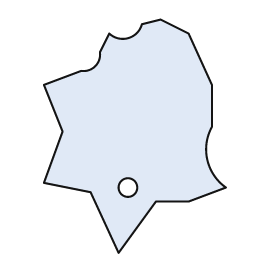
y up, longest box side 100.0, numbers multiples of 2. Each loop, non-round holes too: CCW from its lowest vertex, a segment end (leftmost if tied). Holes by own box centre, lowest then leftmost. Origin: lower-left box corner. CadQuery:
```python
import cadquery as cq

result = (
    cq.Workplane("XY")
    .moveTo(32.0, 0.0)
    .lineTo(48.0, 22.0)
    .lineTo(62.0, 22.0)
    .lineTo(78.0, 28.0)
    .threePointArc((70.0, 40.0), (72.0, 54.0))
    .lineTo(72.0, 72.0)
    .lineTo(62.0, 94.0)
    .lineTo(50.0, 100.0)
    .lineTo(42.0, 98.0)
    .threePointArc((36.0, 92.0), (28.0, 94.0))
    .lineTo(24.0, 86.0)
    .threePointArc((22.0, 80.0), (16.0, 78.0))
    .lineTo(0.0, 72.0)
    .lineTo(8.0, 52.0)
    .lineTo(0.0, 30.0)
    .lineTo(20.0, 26.0)
    .close()
    .moveTo(36.0, 28.0)
    .circle(4.0)
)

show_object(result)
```